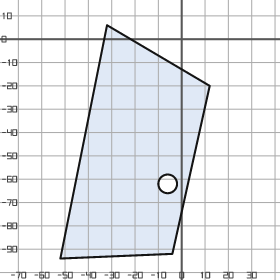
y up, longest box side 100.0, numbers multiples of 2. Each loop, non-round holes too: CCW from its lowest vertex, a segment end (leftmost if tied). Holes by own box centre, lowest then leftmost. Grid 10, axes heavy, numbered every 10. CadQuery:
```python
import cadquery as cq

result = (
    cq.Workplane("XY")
    .moveTo(-52.0, -94.0)
    .lineTo(-4.0, -92.0)
    .lineTo(12.0, -20.0)
    .lineTo(-32.0, 6.0)
    .close()
    .moveTo(-6.0, -62.0)
    .circle(4.0)
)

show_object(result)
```